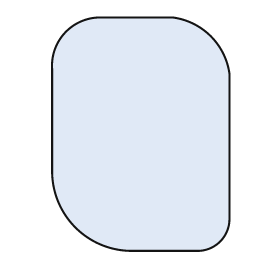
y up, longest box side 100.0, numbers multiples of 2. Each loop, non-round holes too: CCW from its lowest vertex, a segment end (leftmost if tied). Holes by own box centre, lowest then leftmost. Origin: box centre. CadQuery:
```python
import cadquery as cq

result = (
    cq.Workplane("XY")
    .moveTo(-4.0, -50.0)
    .lineTo(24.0, -50.0)
    .threePointArc((34.0, -46.0), (38.0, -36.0))
    .lineTo(38.0, 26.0)
    .threePointArc((30.0, 42.0), (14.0, 50.0))
    .lineTo(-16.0, 50.0)
    .threePointArc((-32.0, 44.0), (-38.0, 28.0))
    .lineTo(-38.0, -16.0)
    .threePointArc((-28.0, -40.0), (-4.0, -50.0))
    .close()
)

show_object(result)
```